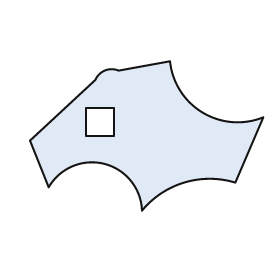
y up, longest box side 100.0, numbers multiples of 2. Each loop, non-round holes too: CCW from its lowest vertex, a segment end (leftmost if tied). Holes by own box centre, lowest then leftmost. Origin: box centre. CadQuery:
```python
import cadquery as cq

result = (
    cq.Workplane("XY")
    .moveTo(-2.0, -32.0)
    .threePointArc((16.0, -20.0), (38.0, -20.0))
    .lineTo(50.0, 8.0)
    .threePointArc((24.0, 10.0), (10.0, 32.0))
    .lineTo(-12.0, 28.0)
    .threePointArc((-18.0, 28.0), (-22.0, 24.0))
    .lineTo(-50.0, -2.0)
    .lineTo(-42.0, -22.0)
    .threePointArc((-18.0, -12.0), (-2.0, -32.0))
    .close()
    .moveTo(-26.0, 0.0)
    .lineTo(-14.0, 0.0)
    .lineTo(-14.0, 12.0)
    .lineTo(-26.0, 12.0)
    .close()
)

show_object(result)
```